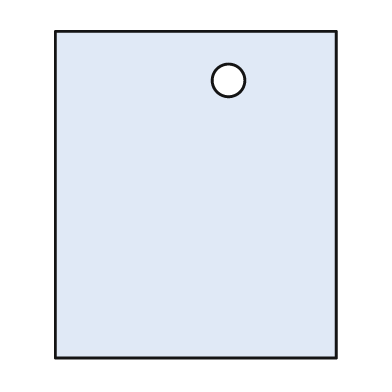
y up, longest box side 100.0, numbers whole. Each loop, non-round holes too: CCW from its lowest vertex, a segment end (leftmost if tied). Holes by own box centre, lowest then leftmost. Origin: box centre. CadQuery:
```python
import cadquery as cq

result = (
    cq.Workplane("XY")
    .moveTo(-43.0, -50.0)
    .lineTo(43.0, -50.0)
    .lineTo(43.0, 50.0)
    .lineTo(-43.0, 50.0)
    .close()
    .moveTo(10.0, 35.0)
    .circle(5.0)
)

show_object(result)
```